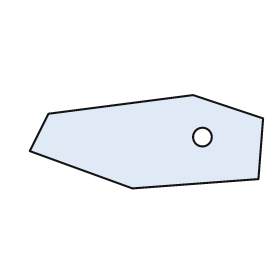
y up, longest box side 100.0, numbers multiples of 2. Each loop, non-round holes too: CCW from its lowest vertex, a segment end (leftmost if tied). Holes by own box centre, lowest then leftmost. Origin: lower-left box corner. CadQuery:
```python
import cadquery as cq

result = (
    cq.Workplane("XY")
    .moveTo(44.0, 0.0)
    .lineTo(98.0, 4.0)
    .lineTo(100.0, 30.0)
    .lineTo(70.0, 40.0)
    .lineTo(8.0, 32.0)
    .lineTo(0.0, 16.0)
    .close()
    .moveTo(74.0, 22.0)
    .circle(4.0)
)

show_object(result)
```